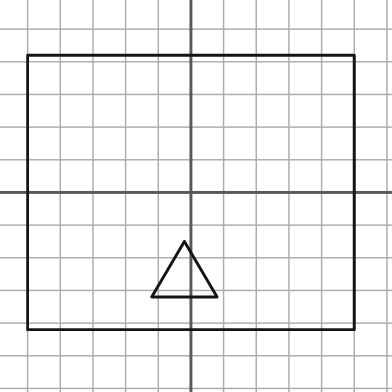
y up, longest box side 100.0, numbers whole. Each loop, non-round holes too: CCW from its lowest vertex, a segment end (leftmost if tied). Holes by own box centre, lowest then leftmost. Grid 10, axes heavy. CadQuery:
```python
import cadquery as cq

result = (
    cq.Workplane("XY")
    .moveTo(-50.0, -42.0)
    .lineTo(50.0, -42.0)
    .lineTo(50.0, 42.0)
    .lineTo(-50.0, 42.0)
    .close()
    .moveTo(-12.0, -32.0)
    .lineTo(8.0, -32.0)
    .lineTo(-2.0, -15.0)
    .close()
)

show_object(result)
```